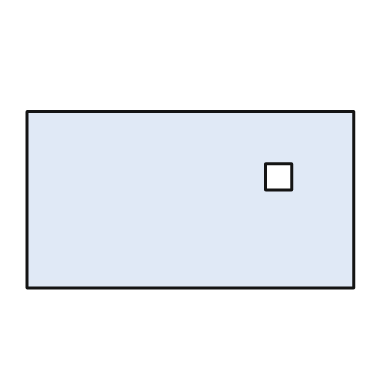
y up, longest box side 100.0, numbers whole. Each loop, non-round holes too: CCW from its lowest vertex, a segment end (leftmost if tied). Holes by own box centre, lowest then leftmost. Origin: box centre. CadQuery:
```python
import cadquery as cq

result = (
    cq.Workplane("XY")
    .moveTo(-50.0, -27.0)
    .lineTo(50.0, -27.0)
    .lineTo(50.0, 27.0)
    .lineTo(-50.0, 27.0)
    .close()
    .moveTo(23.0, 3.0)
    .lineTo(31.0, 3.0)
    .lineTo(31.0, 11.0)
    .lineTo(23.0, 11.0)
    .close()
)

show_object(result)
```